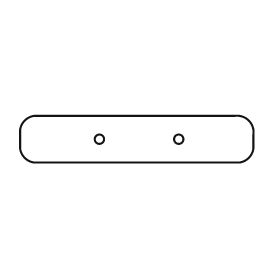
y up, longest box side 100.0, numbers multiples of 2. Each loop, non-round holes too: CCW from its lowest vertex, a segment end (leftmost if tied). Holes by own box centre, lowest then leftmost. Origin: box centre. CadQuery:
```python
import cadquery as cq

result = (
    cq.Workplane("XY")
    .moveTo(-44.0, -10.0)
    .lineTo(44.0, -10.0)
    .threePointArc((48.0, -8.0), (50.0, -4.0))
    .lineTo(50.0, 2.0)
    .threePointArc((48.0, 8.0), (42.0, 10.0))
    .lineTo(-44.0, 10.0)
    .threePointArc((-48.0, 8.0), (-50.0, 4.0))
    .lineTo(-50.0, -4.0)
    .threePointArc((-48.0, -8.0), (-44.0, -10.0))
    .close()
    .moveTo(-16.0, 0.0)
    .circle(2.0)
    .moveTo(18.0, 0.0)
    .circle(2.0)
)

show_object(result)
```